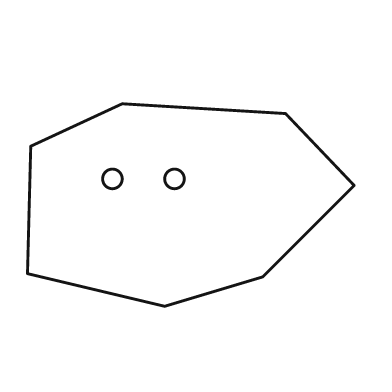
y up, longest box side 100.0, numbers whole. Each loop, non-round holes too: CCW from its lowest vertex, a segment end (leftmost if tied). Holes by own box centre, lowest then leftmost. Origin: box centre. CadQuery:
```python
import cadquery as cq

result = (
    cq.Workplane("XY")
    .moveTo(-8.0, -31.0)
    .lineTo(22.0, -22.0)
    .lineTo(50.0, 6.0)
    .lineTo(29.0, 28.0)
    .lineTo(-21.0, 31.0)
    .lineTo(-49.0, 18.0)
    .lineTo(-50.0, -21.0)
    .close()
    .moveTo(-24.0, 8.0)
    .circle(3.0)
    .moveTo(-5.0, 8.0)
    .circle(3.0)
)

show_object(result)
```